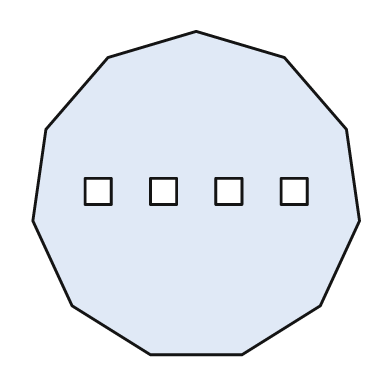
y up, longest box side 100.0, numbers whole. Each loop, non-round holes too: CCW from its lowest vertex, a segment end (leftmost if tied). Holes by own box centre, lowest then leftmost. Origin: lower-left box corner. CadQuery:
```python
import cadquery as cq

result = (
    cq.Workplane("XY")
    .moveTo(36.0, 0.0)
    .lineTo(64.0, 0.0)
    .lineTo(88.0, 15.0)
    .lineTo(100.0, 41.0)
    .lineTo(96.0, 69.0)
    .lineTo(77.0, 91.0)
    .lineTo(50.0, 99.0)
    .lineTo(23.0, 91.0)
    .lineTo(4.0, 69.0)
    .lineTo(0.0, 41.0)
    .lineTo(12.0, 15.0)
    .close()
    .moveTo(16.0, 46.0)
    .lineTo(24.0, 46.0)
    .lineTo(24.0, 54.0)
    .lineTo(16.0, 54.0)
    .close()
    .moveTo(36.0, 46.0)
    .lineTo(44.0, 46.0)
    .lineTo(44.0, 54.0)
    .lineTo(36.0, 54.0)
    .close()
    .moveTo(56.0, 46.0)
    .lineTo(64.0, 46.0)
    .lineTo(64.0, 54.0)
    .lineTo(56.0, 54.0)
    .close()
    .moveTo(76.0, 46.0)
    .lineTo(84.0, 46.0)
    .lineTo(84.0, 54.0)
    .lineTo(76.0, 54.0)
    .close()
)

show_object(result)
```